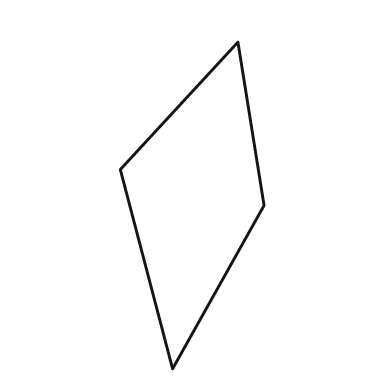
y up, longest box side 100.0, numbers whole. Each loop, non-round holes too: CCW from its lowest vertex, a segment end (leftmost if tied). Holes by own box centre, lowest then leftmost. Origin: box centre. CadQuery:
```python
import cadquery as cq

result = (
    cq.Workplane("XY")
    .moveTo(-6.0, -50.0)
    .lineTo(22.0, 0.0)
    .lineTo(14.0, 50.0)
    .lineTo(-22.0, 11.0)
    .close()
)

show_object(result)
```